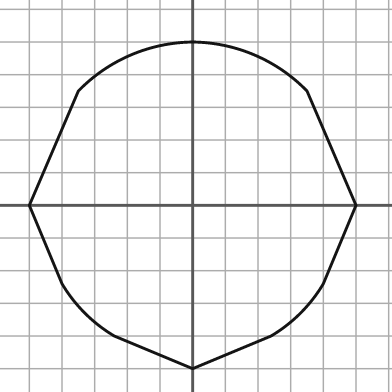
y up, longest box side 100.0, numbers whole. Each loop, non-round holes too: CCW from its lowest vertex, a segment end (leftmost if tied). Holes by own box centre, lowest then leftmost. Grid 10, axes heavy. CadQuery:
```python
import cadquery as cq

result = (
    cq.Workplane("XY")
    .moveTo(0.0, -50.0)
    .lineTo(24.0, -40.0)
    .threePointArc((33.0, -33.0), (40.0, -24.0))
    .lineTo(50.0, 0.0)
    .lineTo(35.0, 35.0)
    .threePointArc((19.0, 46.0), (0.0, 50.0))
    .threePointArc((-19.0, 46.0), (-35.0, 35.0))
    .lineTo(-50.0, 0.0)
    .lineTo(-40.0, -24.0)
    .threePointArc((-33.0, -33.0), (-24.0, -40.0))
    .close()
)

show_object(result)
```